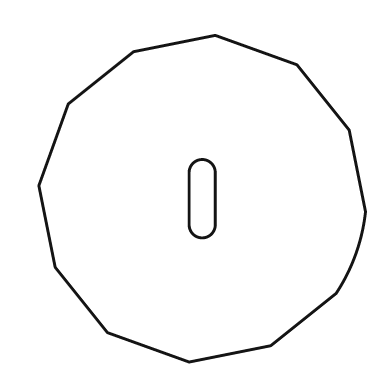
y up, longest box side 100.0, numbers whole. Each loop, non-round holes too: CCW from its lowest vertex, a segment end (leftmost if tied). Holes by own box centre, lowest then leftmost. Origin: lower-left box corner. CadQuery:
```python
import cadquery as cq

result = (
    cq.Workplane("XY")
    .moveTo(46.0, 0.0)
    .lineTo(71.0, 5.0)
    .lineTo(91.0, 21.0)
    .threePointArc((97.0, 33.0), (100.0, 46.0))
    .lineTo(95.0, 71.0)
    .lineTo(79.0, 91.0)
    .lineTo(54.0, 100.0)
    .lineTo(29.0, 95.0)
    .lineTo(9.0, 79.0)
    .lineTo(0.0, 54.0)
    .lineTo(5.0, 29.0)
    .lineTo(21.0, 9.0)
    .close()
    .moveTo(46.0, 42.0)
    .threePointArc((50.0, 38.0), (54.0, 42.0))
    .lineTo(54.0, 58.0)
    .threePointArc((50.0, 62.0), (46.0, 58.0))
    .close()
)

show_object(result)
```